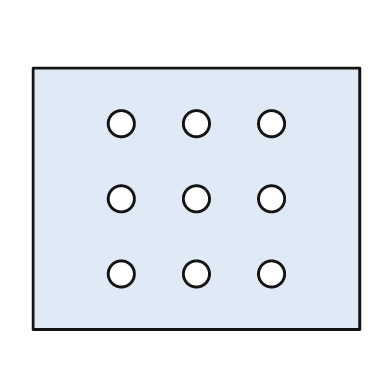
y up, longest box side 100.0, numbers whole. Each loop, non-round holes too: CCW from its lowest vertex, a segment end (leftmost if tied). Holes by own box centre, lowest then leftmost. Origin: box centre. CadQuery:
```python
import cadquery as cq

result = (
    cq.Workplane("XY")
    .moveTo(-50.0, -40.0)
    .lineTo(50.0, -40.0)
    .lineTo(50.0, 40.0)
    .lineTo(-50.0, 40.0)
    .close()
    .moveTo(-23.0, -23.0)
    .circle(4.0)
    .moveTo(0.0, -23.0)
    .circle(4.0)
    .moveTo(23.0, -23.0)
    .circle(4.0)
    .moveTo(-23.0, 0.0)
    .circle(4.0)
    .moveTo(0.0, 0.0)
    .circle(4.0)
    .moveTo(23.0, 0.0)
    .circle(4.0)
    .moveTo(-23.0, 23.0)
    .circle(4.0)
    .moveTo(0.0, 23.0)
    .circle(4.0)
    .moveTo(23.0, 23.0)
    .circle(4.0)
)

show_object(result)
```